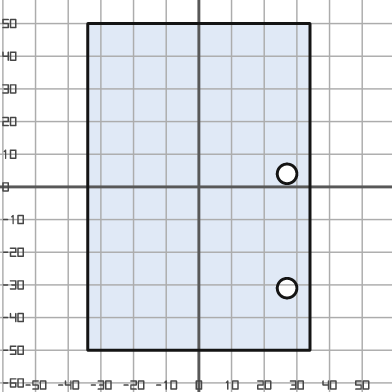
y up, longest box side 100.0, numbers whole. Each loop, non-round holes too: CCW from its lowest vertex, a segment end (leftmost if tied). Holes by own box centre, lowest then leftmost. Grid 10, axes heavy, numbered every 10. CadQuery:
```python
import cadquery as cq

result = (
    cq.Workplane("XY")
    .moveTo(-34.0, -50.0)
    .lineTo(34.0, -50.0)
    .lineTo(34.0, 50.0)
    .lineTo(-34.0, 50.0)
    .close()
    .moveTo(27.0, -31.0)
    .circle(3.0)
    .moveTo(27.0, 4.0)
    .circle(3.0)
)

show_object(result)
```